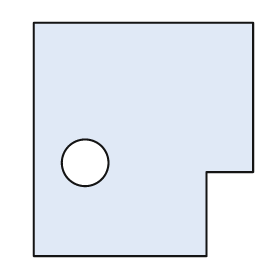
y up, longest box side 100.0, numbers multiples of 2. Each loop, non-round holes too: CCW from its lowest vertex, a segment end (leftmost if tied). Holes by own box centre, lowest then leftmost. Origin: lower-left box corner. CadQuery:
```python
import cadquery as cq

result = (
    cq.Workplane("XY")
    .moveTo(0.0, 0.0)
    .lineTo(74.0, 0.0)
    .lineTo(74.0, 36.0)
    .lineTo(94.0, 36.0)
    .lineTo(94.0, 100.0)
    .lineTo(0.0, 100.0)
    .close()
    .moveTo(22.0, 40.0)
    .circle(10.0)
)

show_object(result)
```